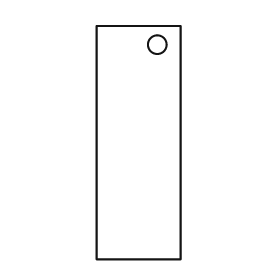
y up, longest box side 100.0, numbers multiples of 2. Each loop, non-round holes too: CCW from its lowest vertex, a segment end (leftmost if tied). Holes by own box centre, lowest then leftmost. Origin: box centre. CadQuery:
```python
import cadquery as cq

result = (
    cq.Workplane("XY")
    .moveTo(-18.0, -50.0)
    .lineTo(18.0, -50.0)
    .lineTo(18.0, 50.0)
    .lineTo(-18.0, 50.0)
    .close()
    .moveTo(8.0, 42.0)
    .circle(4.0)
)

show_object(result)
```